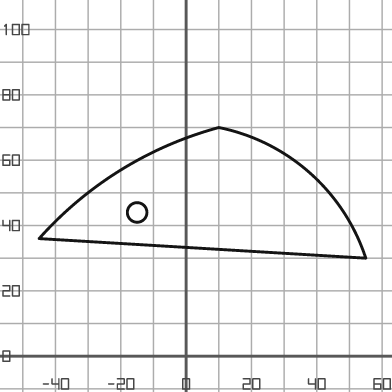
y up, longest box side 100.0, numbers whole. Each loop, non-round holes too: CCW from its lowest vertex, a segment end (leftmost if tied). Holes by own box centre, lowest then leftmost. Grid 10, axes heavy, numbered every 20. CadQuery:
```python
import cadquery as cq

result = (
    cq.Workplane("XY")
    .moveTo(55.0, 30.0)
    .threePointArc((38.0, 56.0), (10.0, 70.0))
    .threePointArc((-20.0, 57.0), (-45.0, 36.0))
    .close()
    .moveTo(-15.0, 44.0)
    .circle(3.0)
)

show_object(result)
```